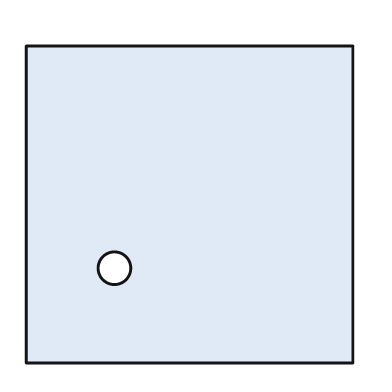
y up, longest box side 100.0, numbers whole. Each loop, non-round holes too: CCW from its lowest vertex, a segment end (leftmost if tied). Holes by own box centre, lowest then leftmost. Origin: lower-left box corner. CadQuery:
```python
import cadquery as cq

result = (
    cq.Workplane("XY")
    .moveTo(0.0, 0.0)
    .lineTo(100.0, 0.0)
    .lineTo(100.0, 97.0)
    .lineTo(0.0, 97.0)
    .close()
    .moveTo(27.0, 29.0)
    .circle(5.0)
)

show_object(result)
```